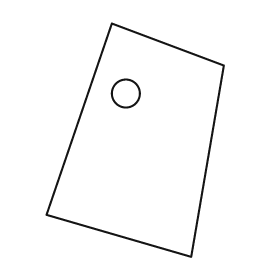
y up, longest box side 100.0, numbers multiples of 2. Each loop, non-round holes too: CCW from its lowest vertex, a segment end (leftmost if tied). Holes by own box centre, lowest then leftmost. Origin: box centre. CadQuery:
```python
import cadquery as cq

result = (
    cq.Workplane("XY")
    .moveTo(24.0, -50.0)
    .lineTo(38.0, 32.0)
    .lineTo(-10.0, 50.0)
    .lineTo(-38.0, -32.0)
    .close()
    .moveTo(-4.0, 20.0)
    .circle(6.0)
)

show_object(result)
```